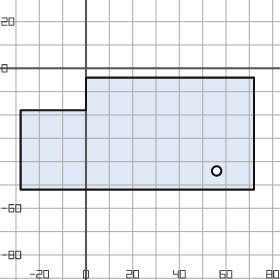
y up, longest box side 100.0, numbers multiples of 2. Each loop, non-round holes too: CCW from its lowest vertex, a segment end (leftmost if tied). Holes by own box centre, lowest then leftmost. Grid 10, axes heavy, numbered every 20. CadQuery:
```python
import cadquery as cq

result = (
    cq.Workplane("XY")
    .moveTo(-28.0, -52.0)
    .lineTo(72.0, -52.0)
    .lineTo(72.0, -4.0)
    .lineTo(0.0, -4.0)
    .lineTo(0.0, -18.0)
    .lineTo(-28.0, -18.0)
    .close()
    .moveTo(56.0, -44.0)
    .circle(2.0)
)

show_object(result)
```